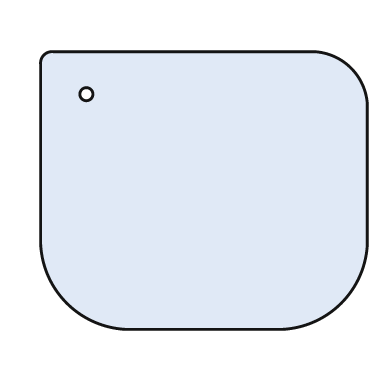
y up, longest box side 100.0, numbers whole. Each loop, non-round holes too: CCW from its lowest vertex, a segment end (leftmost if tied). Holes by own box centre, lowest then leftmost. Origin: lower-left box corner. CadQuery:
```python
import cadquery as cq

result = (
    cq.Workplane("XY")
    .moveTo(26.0, 0.0)
    .lineTo(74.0, 0.0)
    .threePointArc((92.0, 8.0), (100.0, 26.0))
    .lineTo(100.0, 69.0)
    .threePointArc((95.0, 80.0), (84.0, 85.0))
    .lineTo(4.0, 85.0)
    .threePointArc((1.0, 84.0), (0.0, 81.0))
    .lineTo(0.0, 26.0)
    .threePointArc((8.0, 8.0), (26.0, 0.0))
    .close()
    .moveTo(14.0, 72.0)
    .circle(2.0)
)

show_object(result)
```